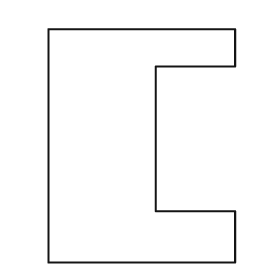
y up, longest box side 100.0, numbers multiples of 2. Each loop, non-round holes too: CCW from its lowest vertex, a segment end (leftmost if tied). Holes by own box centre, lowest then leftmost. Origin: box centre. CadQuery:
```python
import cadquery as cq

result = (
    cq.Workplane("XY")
    .moveTo(-40.0, -50.0)
    .lineTo(40.0, -50.0)
    .lineTo(40.0, -28.0)
    .lineTo(6.0, -28.0)
    .lineTo(6.0, 34.0)
    .lineTo(40.0, 34.0)
    .lineTo(40.0, 50.0)
    .lineTo(-40.0, 50.0)
    .close()
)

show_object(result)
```